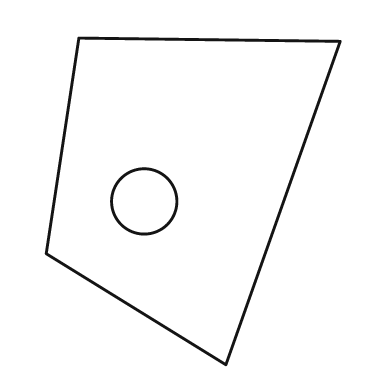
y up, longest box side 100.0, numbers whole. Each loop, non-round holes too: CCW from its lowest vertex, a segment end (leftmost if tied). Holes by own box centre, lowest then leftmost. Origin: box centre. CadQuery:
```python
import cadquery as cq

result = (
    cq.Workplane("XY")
    .moveTo(10.0, -50.0)
    .lineTo(45.0, 49.0)
    .lineTo(-35.0, 50.0)
    .lineTo(-45.0, -16.0)
    .close()
    .moveTo(-15.0, 0.0)
    .circle(10.0)
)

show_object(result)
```